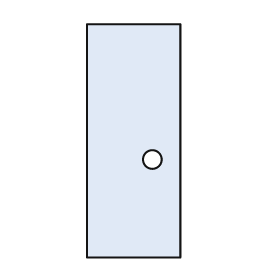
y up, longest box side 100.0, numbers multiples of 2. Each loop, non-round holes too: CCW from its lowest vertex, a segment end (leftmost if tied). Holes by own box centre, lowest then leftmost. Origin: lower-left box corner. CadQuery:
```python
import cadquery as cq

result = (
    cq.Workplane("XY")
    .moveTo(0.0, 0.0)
    .lineTo(40.0, 0.0)
    .lineTo(40.0, 100.0)
    .lineTo(0.0, 100.0)
    .close()
    .moveTo(28.0, 42.0)
    .circle(4.0)
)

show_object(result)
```